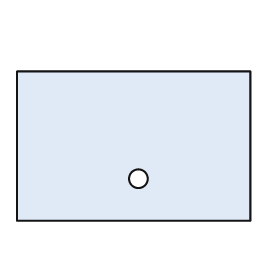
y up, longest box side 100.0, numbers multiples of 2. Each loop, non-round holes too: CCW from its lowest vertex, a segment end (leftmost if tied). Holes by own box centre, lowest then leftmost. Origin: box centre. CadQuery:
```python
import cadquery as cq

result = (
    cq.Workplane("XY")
    .moveTo(-50.0, -32.0)
    .lineTo(50.0, -32.0)
    .lineTo(50.0, 32.0)
    .lineTo(-50.0, 32.0)
    .close()
    .moveTo(2.0, -14.0)
    .circle(4.0)
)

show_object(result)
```